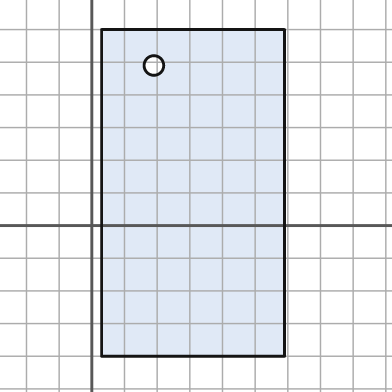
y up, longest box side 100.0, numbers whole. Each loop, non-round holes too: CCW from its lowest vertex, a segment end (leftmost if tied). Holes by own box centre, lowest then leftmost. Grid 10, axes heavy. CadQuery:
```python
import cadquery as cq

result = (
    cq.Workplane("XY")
    .moveTo(3.0, -40.0)
    .lineTo(59.0, -40.0)
    .lineTo(59.0, 60.0)
    .lineTo(3.0, 60.0)
    .close()
    .moveTo(19.0, 49.0)
    .circle(3.0)
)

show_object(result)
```